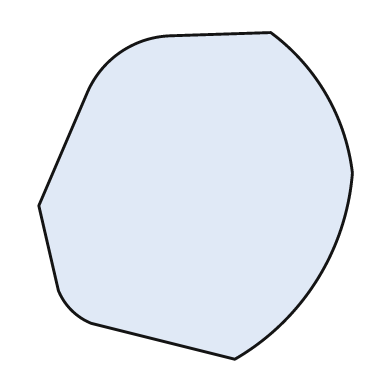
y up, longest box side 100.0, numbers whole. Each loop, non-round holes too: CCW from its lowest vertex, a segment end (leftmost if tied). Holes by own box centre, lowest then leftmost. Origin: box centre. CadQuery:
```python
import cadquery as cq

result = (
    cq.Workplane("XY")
    .moveTo(12.0, -50.0)
    .threePointArc((37.0, -26.0), (48.0, 7.0))
    .threePointArc((40.0, 31.0), (23.0, 50.0))
    .lineTo(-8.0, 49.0)
    .threePointArc((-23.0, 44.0), (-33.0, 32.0))
    .lineTo(-48.0, -3.0)
    .lineTo(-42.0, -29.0)
    .threePointArc((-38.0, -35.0), (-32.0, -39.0))
    .close()
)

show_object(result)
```